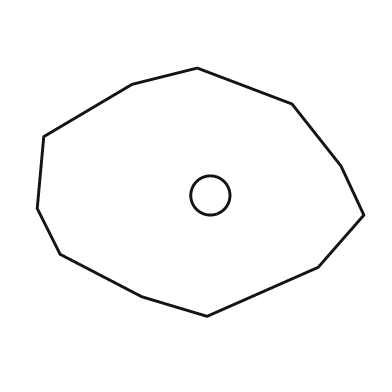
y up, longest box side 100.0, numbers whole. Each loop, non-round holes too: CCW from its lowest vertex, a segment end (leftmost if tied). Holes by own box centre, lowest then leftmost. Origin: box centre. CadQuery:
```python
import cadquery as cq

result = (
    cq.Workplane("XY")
    .moveTo(2.0, -38.0)
    .lineTo(36.0, -23.0)
    .lineTo(50.0, -7.0)
    .lineTo(43.0, 8.0)
    .lineTo(28.0, 27.0)
    .lineTo(-1.0, 38.0)
    .lineTo(-21.0, 33.0)
    .lineTo(-48.0, 17.0)
    .lineTo(-50.0, -5.0)
    .lineTo(-43.0, -19.0)
    .lineTo(-18.0, -32.0)
    .close()
    .moveTo(3.0, -1.0)
    .circle(6.0)
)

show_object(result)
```